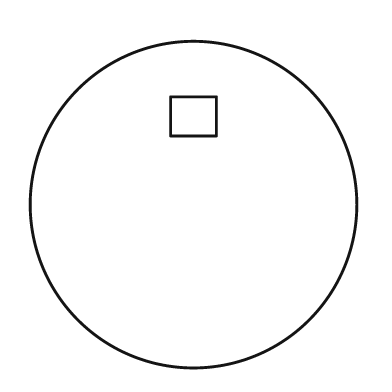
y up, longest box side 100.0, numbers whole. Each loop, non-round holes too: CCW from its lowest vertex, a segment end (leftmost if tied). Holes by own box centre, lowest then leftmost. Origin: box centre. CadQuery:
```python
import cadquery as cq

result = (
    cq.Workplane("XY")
    .moveTo(0.0, 0.0)
    .circle(50.0)
    .moveTo(-7.0, 21.0)
    .lineTo(7.0, 21.0)
    .lineTo(7.0, 33.0)
    .lineTo(-7.0, 33.0)
    .close()
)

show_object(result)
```